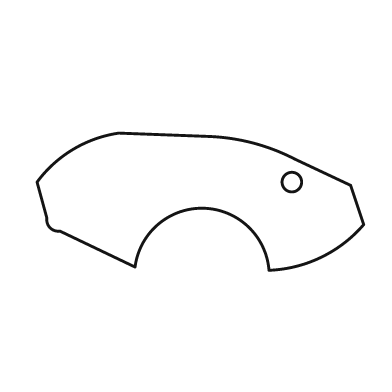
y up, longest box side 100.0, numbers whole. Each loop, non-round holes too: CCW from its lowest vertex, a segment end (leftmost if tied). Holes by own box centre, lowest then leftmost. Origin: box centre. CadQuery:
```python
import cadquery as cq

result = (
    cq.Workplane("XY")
    .moveTo(21.0, -21.0)
    .threePointArc((37.0, -17.0), (50.0, -7.0))
    .lineTo(46.0, 5.0)
    .lineTo(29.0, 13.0)
    .threePointArc((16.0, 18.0), (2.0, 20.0))
    .lineTo(-25.0, 21.0)
    .threePointArc((-39.0, 16.0), (-50.0, 6.0))
    .lineTo(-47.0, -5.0)
    .threePointArc((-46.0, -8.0), (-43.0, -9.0))
    .lineTo(-20.0, -20.0)
    .threePointArc((1.0, -2.0), (21.0, -21.0))
    .close()
    .moveTo(28.0, 6.0)
    .circle(3.0)
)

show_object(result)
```